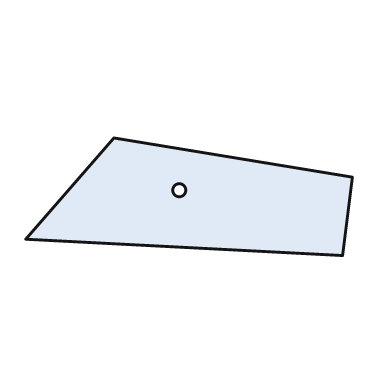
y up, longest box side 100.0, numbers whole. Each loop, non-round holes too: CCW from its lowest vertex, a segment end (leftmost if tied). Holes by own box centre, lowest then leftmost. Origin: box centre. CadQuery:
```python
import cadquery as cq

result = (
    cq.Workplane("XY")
    .moveTo(47.0, -18.0)
    .lineTo(50.0, 6.0)
    .lineTo(-23.0, 18.0)
    .lineTo(-50.0, -13.0)
    .close()
    .moveTo(-3.0, 2.0)
    .circle(2.0)
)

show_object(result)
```